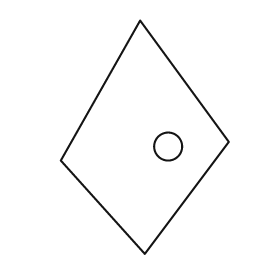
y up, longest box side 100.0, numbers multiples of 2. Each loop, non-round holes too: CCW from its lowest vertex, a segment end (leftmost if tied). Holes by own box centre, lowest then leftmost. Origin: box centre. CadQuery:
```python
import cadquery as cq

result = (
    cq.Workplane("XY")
    .moveTo(0.0, -50.0)
    .lineTo(36.0, -2.0)
    .lineTo(-2.0, 50.0)
    .lineTo(-36.0, -10.0)
    .close()
    .moveTo(10.0, -4.0)
    .circle(6.0)
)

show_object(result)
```